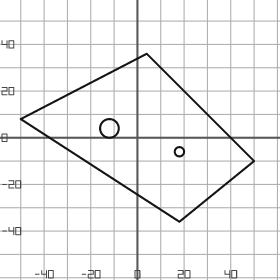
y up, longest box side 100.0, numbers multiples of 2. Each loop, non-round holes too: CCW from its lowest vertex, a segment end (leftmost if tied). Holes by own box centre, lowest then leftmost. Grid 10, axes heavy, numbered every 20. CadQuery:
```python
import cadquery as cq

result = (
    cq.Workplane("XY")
    .moveTo(18.0, -36.0)
    .lineTo(50.0, -10.0)
    .lineTo(4.0, 36.0)
    .lineTo(-50.0, 8.0)
    .close()
    .moveTo(18.0, -6.0)
    .circle(2.0)
    .moveTo(-12.0, 4.0)
    .circle(4.0)
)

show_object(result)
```